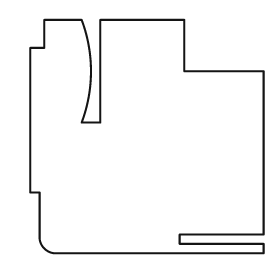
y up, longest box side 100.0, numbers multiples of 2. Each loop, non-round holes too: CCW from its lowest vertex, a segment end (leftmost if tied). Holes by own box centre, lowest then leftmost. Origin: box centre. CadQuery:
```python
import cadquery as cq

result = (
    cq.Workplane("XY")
    .moveTo(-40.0, -50.0)
    .lineTo(50.0, -50.0)
    .lineTo(50.0, -46.0)
    .lineTo(14.0, -46.0)
    .lineTo(14.0, -42.0)
    .lineTo(50.0, -42.0)
    .lineTo(50.0, 28.0)
    .lineTo(16.0, 28.0)
    .lineTo(16.0, 50.0)
    .lineTo(-20.0, 50.0)
    .lineTo(-20.0, 6.0)
    .lineTo(-28.0, 6.0)
    .threePointArc((-24.0, 28.0), (-28.0, 50.0))
    .lineTo(-44.0, 50.0)
    .lineTo(-44.0, 38.0)
    .lineTo(-50.0, 38.0)
    .lineTo(-50.0, -24.0)
    .lineTo(-46.0, -24.0)
    .lineTo(-46.0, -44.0)
    .threePointArc((-44.0, -48.0), (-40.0, -50.0))
    .close()
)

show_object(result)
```